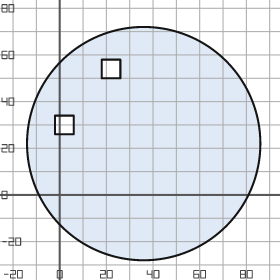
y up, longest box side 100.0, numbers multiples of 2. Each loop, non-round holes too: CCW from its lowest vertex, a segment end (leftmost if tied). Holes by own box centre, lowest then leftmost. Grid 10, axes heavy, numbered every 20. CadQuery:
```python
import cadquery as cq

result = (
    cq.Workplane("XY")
    .moveTo(36.0, 22.0)
    .circle(50.0)
    .moveTo(-2.0, 26.0)
    .lineTo(6.0, 26.0)
    .lineTo(6.0, 34.0)
    .lineTo(-2.0, 34.0)
    .close()
    .moveTo(18.0, 50.0)
    .lineTo(26.0, 50.0)
    .lineTo(26.0, 58.0)
    .lineTo(18.0, 58.0)
    .close()
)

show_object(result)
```